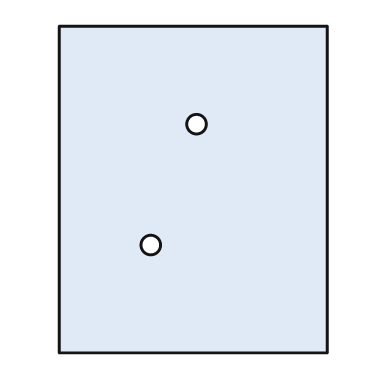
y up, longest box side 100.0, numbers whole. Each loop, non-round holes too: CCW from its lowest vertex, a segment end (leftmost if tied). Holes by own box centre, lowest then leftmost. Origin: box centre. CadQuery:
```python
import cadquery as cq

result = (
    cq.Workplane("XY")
    .moveTo(-41.0, -50.0)
    .lineTo(41.0, -50.0)
    .lineTo(41.0, 50.0)
    .lineTo(-41.0, 50.0)
    .close()
    .moveTo(-13.0, -17.0)
    .circle(3.0)
    .moveTo(1.0, 20.0)
    .circle(3.0)
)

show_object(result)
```